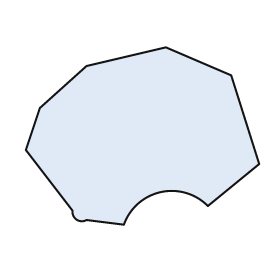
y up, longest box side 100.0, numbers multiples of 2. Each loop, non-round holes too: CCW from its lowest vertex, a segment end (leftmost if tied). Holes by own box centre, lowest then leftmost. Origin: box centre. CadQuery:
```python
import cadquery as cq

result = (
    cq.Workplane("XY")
    .moveTo(-8.0, -38.0)
    .threePointArc((8.0, -24.0), (28.0, -30.0))
    .lineTo(50.0, -12.0)
    .lineTo(38.0, 26.0)
    .lineTo(10.0, 38.0)
    .lineTo(-24.0, 30.0)
    .lineTo(-44.0, 12.0)
    .lineTo(-50.0, -6.0)
    .lineTo(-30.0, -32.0)
    .threePointArc((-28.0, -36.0), (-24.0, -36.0))
    .close()
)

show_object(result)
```